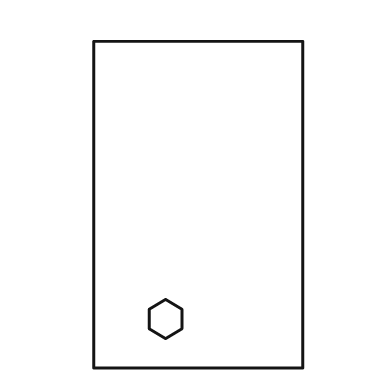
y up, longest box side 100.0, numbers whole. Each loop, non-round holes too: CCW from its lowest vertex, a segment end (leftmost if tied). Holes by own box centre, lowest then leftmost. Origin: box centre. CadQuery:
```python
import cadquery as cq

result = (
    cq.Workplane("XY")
    .moveTo(-32.0, -50.0)
    .lineTo(32.0, -50.0)
    .lineTo(32.0, 50.0)
    .lineTo(-32.0, 50.0)
    .close()
    .moveTo(-10.0, -41.0)
    .lineTo(-5.0, -38.0)
    .lineTo(-5.0, -32.0)
    .lineTo(-10.0, -29.0)
    .lineTo(-15.0, -32.0)
    .lineTo(-15.0, -38.0)
    .close()
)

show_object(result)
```